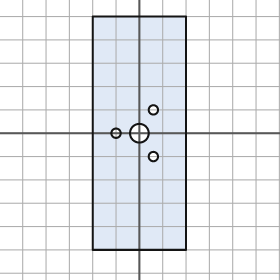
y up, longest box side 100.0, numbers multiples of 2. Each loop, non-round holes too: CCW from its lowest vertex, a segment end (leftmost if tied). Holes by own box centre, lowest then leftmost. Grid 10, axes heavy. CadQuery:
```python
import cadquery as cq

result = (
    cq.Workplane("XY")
    .moveTo(-20.0, -50.0)
    .lineTo(20.0, -50.0)
    .lineTo(20.0, 50.0)
    .lineTo(-20.0, 50.0)
    .close()
    .moveTo(6.0, -10.0)
    .circle(2.0)
    .moveTo(-10.0, 0.0)
    .circle(2.0)
    .moveTo(0.0, 0.0)
    .circle(4.0)
    .moveTo(6.0, 10.0)
    .circle(2.0)
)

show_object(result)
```